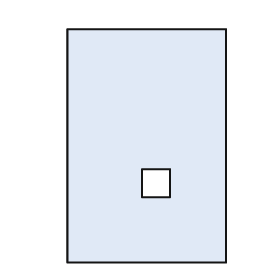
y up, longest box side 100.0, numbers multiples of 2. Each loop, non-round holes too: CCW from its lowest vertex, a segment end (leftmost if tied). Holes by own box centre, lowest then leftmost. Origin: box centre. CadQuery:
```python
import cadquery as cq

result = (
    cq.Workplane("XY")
    .moveTo(-34.0, -50.0)
    .lineTo(34.0, -50.0)
    .lineTo(34.0, 50.0)
    .lineTo(-34.0, 50.0)
    .close()
    .moveTo(-2.0, -22.0)
    .lineTo(10.0, -22.0)
    .lineTo(10.0, -10.0)
    .lineTo(-2.0, -10.0)
    .close()
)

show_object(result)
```